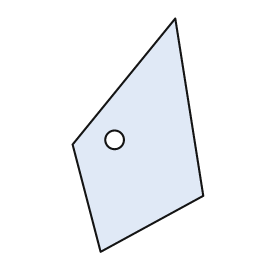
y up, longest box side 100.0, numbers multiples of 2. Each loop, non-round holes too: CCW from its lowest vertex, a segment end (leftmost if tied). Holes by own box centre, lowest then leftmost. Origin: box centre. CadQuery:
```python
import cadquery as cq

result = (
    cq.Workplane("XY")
    .moveTo(-16.0, -50.0)
    .lineTo(28.0, -26.0)
    .lineTo(16.0, 50.0)
    .lineTo(-28.0, -4.0)
    .close()
    .moveTo(-10.0, -2.0)
    .circle(4.0)
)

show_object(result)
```